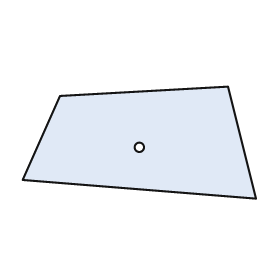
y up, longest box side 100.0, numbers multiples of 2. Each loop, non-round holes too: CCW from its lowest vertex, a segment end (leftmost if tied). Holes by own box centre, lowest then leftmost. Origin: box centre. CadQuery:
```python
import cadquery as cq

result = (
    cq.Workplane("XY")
    .moveTo(50.0, -24.0)
    .lineTo(38.0, 24.0)
    .lineTo(-34.0, 20.0)
    .lineTo(-50.0, -16.0)
    .close()
    .moveTo(0.0, -2.0)
    .circle(2.0)
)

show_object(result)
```